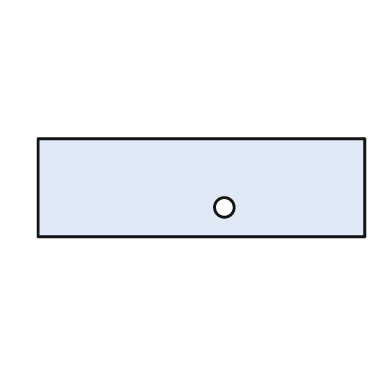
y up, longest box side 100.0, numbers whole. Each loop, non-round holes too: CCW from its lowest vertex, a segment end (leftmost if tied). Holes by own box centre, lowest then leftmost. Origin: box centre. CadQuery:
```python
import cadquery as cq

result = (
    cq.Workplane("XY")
    .moveTo(-50.0, -15.0)
    .lineTo(50.0, -15.0)
    .lineTo(50.0, 15.0)
    .lineTo(-50.0, 15.0)
    .close()
    .moveTo(7.0, -6.0)
    .circle(3.0)
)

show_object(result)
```